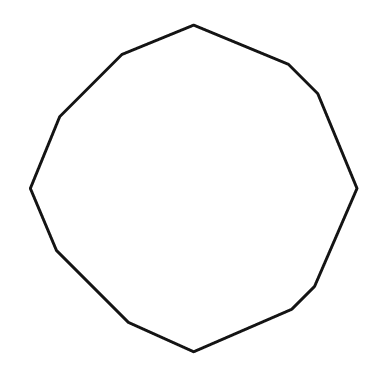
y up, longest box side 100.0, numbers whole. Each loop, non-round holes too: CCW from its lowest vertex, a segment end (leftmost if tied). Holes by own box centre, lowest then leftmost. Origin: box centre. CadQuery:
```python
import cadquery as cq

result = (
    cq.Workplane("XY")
    .moveTo(0.0, -50.0)
    .lineTo(30.0, -37.0)
    .lineTo(37.0, -30.0)
    .lineTo(50.0, 0.0)
    .lineTo(38.0, 29.0)
    .lineTo(29.0, 38.0)
    .lineTo(0.0, 50.0)
    .lineTo(-22.0, 41.0)
    .lineTo(-41.0, 22.0)
    .lineTo(-50.0, 0.0)
    .lineTo(-42.0, -19.0)
    .lineTo(-20.0, -41.0)
    .close()
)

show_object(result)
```